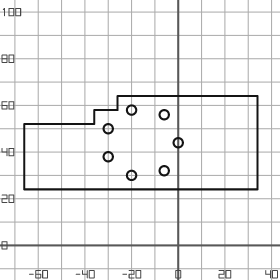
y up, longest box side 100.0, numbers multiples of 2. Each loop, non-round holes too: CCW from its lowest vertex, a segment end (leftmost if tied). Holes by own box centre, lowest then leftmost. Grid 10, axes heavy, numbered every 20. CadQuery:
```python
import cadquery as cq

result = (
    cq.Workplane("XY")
    .moveTo(-66.0, 24.0)
    .lineTo(34.0, 24.0)
    .lineTo(34.0, 64.0)
    .lineTo(-26.0, 64.0)
    .lineTo(-26.0, 58.0)
    .lineTo(-36.0, 58.0)
    .lineTo(-36.0, 52.0)
    .lineTo(-66.0, 52.0)
    .close()
    .moveTo(-20.0, 30.0)
    .circle(2.0)
    .moveTo(-6.0, 32.0)
    .circle(2.0)
    .moveTo(-30.0, 38.0)
    .circle(2.0)
    .moveTo(0.0, 44.0)
    .circle(2.0)
    .moveTo(-30.0, 50.0)
    .circle(2.0)
    .moveTo(-6.0, 56.0)
    .circle(2.0)
    .moveTo(-20.0, 58.0)
    .circle(2.0)
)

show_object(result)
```